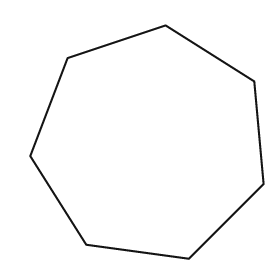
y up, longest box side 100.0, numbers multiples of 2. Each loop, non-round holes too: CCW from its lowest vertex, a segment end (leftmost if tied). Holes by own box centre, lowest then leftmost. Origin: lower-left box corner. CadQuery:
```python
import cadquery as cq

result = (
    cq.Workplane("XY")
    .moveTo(68.0, 0.0)
    .lineTo(100.0, 32.0)
    .lineTo(96.0, 76.0)
    .lineTo(58.0, 100.0)
    .lineTo(16.0, 86.0)
    .lineTo(0.0, 44.0)
    .lineTo(24.0, 6.0)
    .close()
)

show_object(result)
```